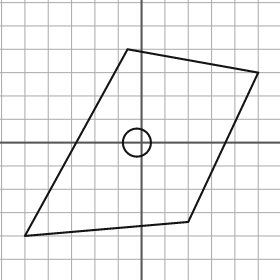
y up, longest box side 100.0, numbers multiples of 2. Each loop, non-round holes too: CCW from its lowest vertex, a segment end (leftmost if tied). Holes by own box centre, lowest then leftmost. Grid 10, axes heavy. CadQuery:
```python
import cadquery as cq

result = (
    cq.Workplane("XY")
    .moveTo(-50.0, -40.0)
    .lineTo(20.0, -34.0)
    .lineTo(50.0, 30.0)
    .lineTo(-6.0, 40.0)
    .close()
    .moveTo(-2.0, 0.0)
    .circle(6.0)
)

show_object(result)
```